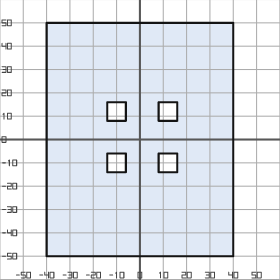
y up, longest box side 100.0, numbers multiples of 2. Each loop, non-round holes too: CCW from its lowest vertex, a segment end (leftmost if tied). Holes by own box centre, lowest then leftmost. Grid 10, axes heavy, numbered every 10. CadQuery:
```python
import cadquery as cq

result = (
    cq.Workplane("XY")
    .moveTo(-40.0, -50.0)
    .lineTo(40.0, -50.0)
    .lineTo(40.0, 50.0)
    .lineTo(-40.0, 50.0)
    .close()
    .moveTo(-14.0, -14.0)
    .lineTo(-6.0, -14.0)
    .lineTo(-6.0, -6.0)
    .lineTo(-14.0, -6.0)
    .close()
    .moveTo(8.0, -14.0)
    .lineTo(16.0, -14.0)
    .lineTo(16.0, -6.0)
    .lineTo(8.0, -6.0)
    .close()
    .moveTo(-14.0, 8.0)
    .lineTo(-6.0, 8.0)
    .lineTo(-6.0, 16.0)
    .lineTo(-14.0, 16.0)
    .close()
    .moveTo(8.0, 8.0)
    .lineTo(16.0, 8.0)
    .lineTo(16.0, 16.0)
    .lineTo(8.0, 16.0)
    .close()
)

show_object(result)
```